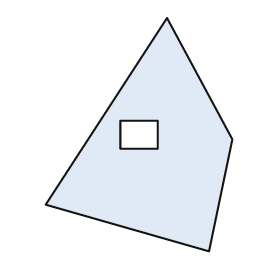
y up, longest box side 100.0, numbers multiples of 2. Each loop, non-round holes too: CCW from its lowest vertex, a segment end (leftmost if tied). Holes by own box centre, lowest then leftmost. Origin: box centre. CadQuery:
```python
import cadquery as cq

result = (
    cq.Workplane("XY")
    .moveTo(30.0, -50.0)
    .lineTo(40.0, -2.0)
    .lineTo(12.0, 50.0)
    .lineTo(-40.0, -30.0)
    .close()
    .moveTo(-8.0, -6.0)
    .lineTo(8.0, -6.0)
    .lineTo(8.0, 6.0)
    .lineTo(-8.0, 6.0)
    .close()
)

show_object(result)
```